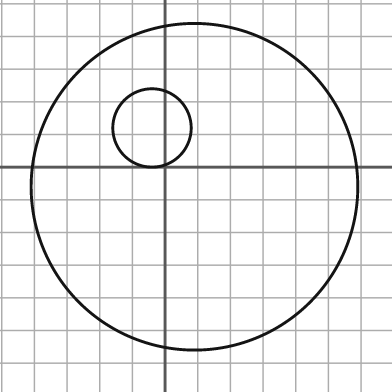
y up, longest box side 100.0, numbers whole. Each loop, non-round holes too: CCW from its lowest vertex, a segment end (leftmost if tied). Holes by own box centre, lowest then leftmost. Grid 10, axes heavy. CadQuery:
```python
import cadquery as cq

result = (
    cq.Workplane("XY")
    .moveTo(9.0, -6.0)
    .circle(50.0)
    .moveTo(-4.0, 12.0)
    .circle(12.0)
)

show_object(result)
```